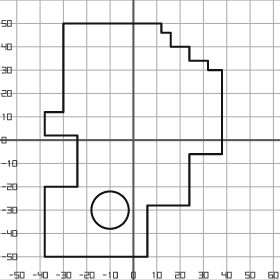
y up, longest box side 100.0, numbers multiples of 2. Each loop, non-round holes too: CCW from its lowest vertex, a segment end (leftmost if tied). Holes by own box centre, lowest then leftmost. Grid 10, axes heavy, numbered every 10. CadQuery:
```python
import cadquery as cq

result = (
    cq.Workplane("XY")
    .moveTo(-38.0, -50.0)
    .lineTo(6.0, -50.0)
    .lineTo(6.0, -28.0)
    .lineTo(24.0, -28.0)
    .lineTo(24.0, -6.0)
    .lineTo(38.0, -6.0)
    .lineTo(38.0, 30.0)
    .lineTo(32.0, 30.0)
    .lineTo(32.0, 34.0)
    .lineTo(24.0, 34.0)
    .lineTo(24.0, 40.0)
    .lineTo(16.0, 40.0)
    .lineTo(16.0, 46.0)
    .lineTo(12.0, 46.0)
    .lineTo(12.0, 50.0)
    .lineTo(-30.0, 50.0)
    .lineTo(-30.0, 12.0)
    .lineTo(-38.0, 12.0)
    .lineTo(-38.0, 2.0)
    .lineTo(-24.0, 2.0)
    .lineTo(-24.0, -20.0)
    .lineTo(-38.0, -20.0)
    .close()
    .moveTo(-10.0, -30.0)
    .circle(8.0)
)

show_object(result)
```